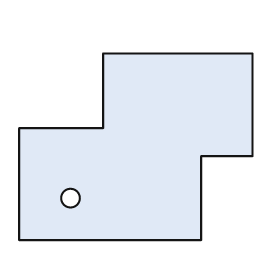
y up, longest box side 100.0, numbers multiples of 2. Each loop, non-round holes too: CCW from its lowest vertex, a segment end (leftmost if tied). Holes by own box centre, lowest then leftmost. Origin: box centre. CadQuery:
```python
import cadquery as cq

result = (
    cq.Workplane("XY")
    .moveTo(-50.0, -40.0)
    .lineTo(28.0, -40.0)
    .lineTo(28.0, -4.0)
    .lineTo(50.0, -4.0)
    .lineTo(50.0, 40.0)
    .lineTo(-14.0, 40.0)
    .lineTo(-14.0, 8.0)
    .lineTo(-50.0, 8.0)
    .close()
    .moveTo(-28.0, -22.0)
    .circle(4.0)
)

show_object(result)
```